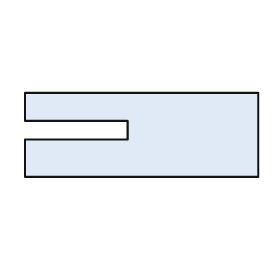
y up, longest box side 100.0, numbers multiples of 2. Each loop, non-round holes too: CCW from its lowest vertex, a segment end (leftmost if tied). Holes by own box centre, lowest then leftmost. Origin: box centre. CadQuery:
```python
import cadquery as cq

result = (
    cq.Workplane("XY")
    .moveTo(-50.0, -18.0)
    .lineTo(50.0, -18.0)
    .lineTo(50.0, 18.0)
    .lineTo(-50.0, 18.0)
    .lineTo(-50.0, 6.0)
    .lineTo(-6.0, 6.0)
    .lineTo(-6.0, -2.0)
    .lineTo(-50.0, -2.0)
    .close()
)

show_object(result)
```